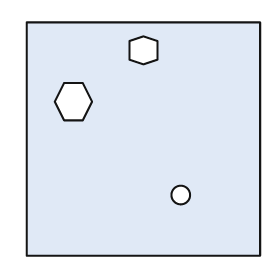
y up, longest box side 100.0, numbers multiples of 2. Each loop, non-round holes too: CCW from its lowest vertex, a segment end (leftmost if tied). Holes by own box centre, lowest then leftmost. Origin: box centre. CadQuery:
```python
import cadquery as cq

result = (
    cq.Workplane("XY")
    .moveTo(-50.0, -50.0)
    .lineTo(50.0, -50.0)
    .lineTo(50.0, 50.0)
    .lineTo(-50.0, 50.0)
    .close()
    .moveTo(16.0, -24.0)
    .circle(4.0)
    .moveTo(-34.0, 8.0)
    .lineTo(-26.0, 8.0)
    .lineTo(-22.0, 16.0)
    .lineTo(-26.0, 24.0)
    .lineTo(-34.0, 24.0)
    .lineTo(-38.0, 16.0)
    .close()
    .moveTo(0.0, 32.0)
    .lineTo(6.0, 34.0)
    .lineTo(6.0, 42.0)
    .lineTo(0.0, 44.0)
    .lineTo(-6.0, 42.0)
    .lineTo(-6.0, 34.0)
    .close()
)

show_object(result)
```